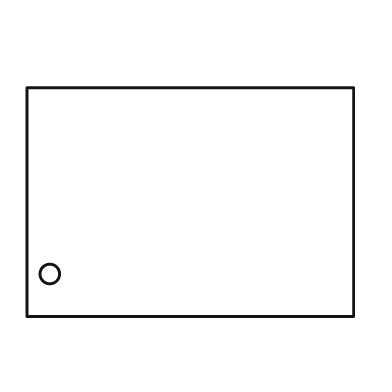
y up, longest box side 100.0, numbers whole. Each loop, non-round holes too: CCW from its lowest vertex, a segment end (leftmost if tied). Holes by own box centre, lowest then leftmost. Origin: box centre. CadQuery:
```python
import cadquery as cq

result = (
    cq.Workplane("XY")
    .moveTo(-50.0, -35.0)
    .lineTo(50.0, -35.0)
    .lineTo(50.0, 35.0)
    .lineTo(-50.0, 35.0)
    .close()
    .moveTo(-43.0, -22.0)
    .circle(3.0)
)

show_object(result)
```